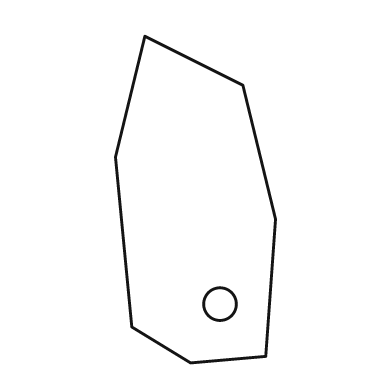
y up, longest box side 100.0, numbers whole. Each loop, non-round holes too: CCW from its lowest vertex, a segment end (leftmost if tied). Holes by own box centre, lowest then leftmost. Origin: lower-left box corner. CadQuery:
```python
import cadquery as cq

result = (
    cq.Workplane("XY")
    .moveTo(23.0, 0.0)
    .lineTo(46.0, 2.0)
    .lineTo(49.0, 44.0)
    .lineTo(39.0, 85.0)
    .lineTo(9.0, 100.0)
    .lineTo(0.0, 63.0)
    .lineTo(5.0, 11.0)
    .close()
    .moveTo(32.0, 18.0)
    .circle(5.0)
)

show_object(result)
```